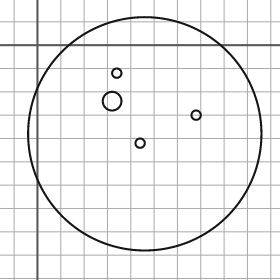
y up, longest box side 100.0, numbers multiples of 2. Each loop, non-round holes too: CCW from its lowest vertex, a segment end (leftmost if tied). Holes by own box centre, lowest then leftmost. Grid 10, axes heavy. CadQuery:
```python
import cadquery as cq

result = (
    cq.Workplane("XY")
    .moveTo(46.0, -38.0)
    .circle(50.0)
    .moveTo(44.0, -42.0)
    .circle(2.0)
    .moveTo(68.0, -30.0)
    .circle(2.0)
    .moveTo(32.0, -24.0)
    .circle(4.0)
    .moveTo(34.0, -12.0)
    .circle(2.0)
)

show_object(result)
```